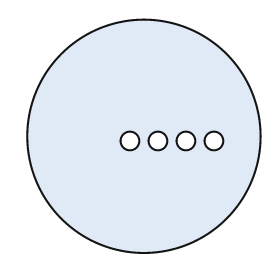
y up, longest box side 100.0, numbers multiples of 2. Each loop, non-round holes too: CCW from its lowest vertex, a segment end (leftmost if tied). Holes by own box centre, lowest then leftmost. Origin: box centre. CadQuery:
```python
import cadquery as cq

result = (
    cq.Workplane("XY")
    .moveTo(0.0, 0.0)
    .circle(50.0)
    .moveTo(-6.0, -2.0)
    .circle(4.0)
    .moveTo(6.0, -2.0)
    .circle(4.0)
    .moveTo(18.0, -2.0)
    .circle(4.0)
    .moveTo(30.0, -2.0)
    .circle(4.0)
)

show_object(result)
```